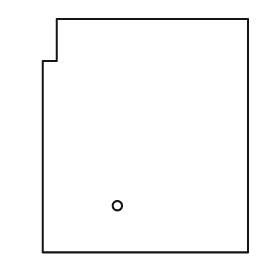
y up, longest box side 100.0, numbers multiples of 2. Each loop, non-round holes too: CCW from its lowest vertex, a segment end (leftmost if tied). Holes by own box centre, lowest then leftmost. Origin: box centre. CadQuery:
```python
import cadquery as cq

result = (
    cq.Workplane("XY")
    .moveTo(-44.0, -50.0)
    .lineTo(44.0, -50.0)
    .lineTo(44.0, 50.0)
    .lineTo(-38.0, 50.0)
    .lineTo(-38.0, 32.0)
    .lineTo(-44.0, 32.0)
    .close()
    .moveTo(-12.0, -30.0)
    .circle(2.0)
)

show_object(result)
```